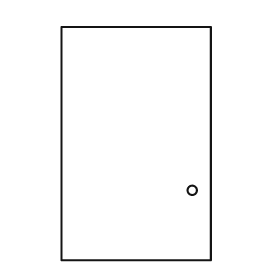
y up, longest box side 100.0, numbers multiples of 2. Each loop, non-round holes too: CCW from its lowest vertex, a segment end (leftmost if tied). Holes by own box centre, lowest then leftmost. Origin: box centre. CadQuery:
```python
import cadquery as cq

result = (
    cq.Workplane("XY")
    .moveTo(-32.0, -50.0)
    .lineTo(32.0, -50.0)
    .lineTo(32.0, 50.0)
    .lineTo(-32.0, 50.0)
    .close()
    .moveTo(24.0, -20.0)
    .circle(2.0)
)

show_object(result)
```